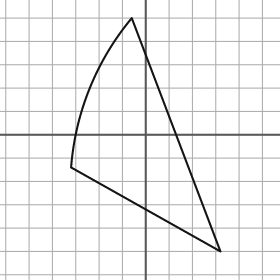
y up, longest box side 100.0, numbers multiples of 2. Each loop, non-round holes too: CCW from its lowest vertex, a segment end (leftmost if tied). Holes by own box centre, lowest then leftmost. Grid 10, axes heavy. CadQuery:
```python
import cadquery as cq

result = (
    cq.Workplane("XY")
    .moveTo(32.0, -50.0)
    .lineTo(-6.0, 50.0)
    .threePointArc((-24.0, 20.0), (-32.0, -14.0))
    .close()
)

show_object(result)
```